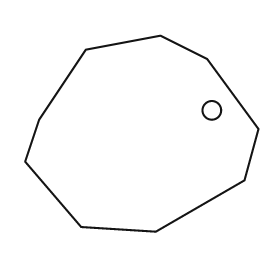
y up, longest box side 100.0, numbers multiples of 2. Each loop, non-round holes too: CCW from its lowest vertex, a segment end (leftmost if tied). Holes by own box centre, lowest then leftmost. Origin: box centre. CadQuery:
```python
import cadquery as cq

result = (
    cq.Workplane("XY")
    .moveTo(6.0, -42.0)
    .lineTo(44.0, -20.0)
    .lineTo(50.0, 2.0)
    .lineTo(28.0, 32.0)
    .lineTo(8.0, 42.0)
    .lineTo(-24.0, 36.0)
    .lineTo(-44.0, 6.0)
    .lineTo(-50.0, -12.0)
    .lineTo(-26.0, -40.0)
    .close()
    .moveTo(30.0, 10.0)
    .circle(4.0)
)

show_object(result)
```